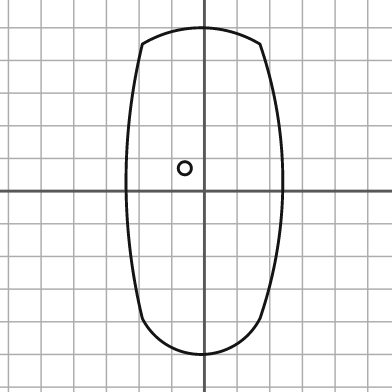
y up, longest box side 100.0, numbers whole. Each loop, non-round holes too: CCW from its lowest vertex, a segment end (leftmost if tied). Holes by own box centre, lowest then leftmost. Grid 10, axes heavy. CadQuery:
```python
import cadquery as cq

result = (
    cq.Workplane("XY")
    .moveTo(-19.0, -39.0)
    .threePointArc((-1.0, -50.0), (17.0, -39.0))
    .threePointArc((24.0, 3.0), (17.0, 45.0))
    .threePointArc((-1.0, 50.0), (-19.0, 45.0))
    .threePointArc((-24.0, 3.0), (-19.0, -39.0))
    .close()
    .moveTo(-6.0, 7.0)
    .circle(2.0)
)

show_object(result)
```